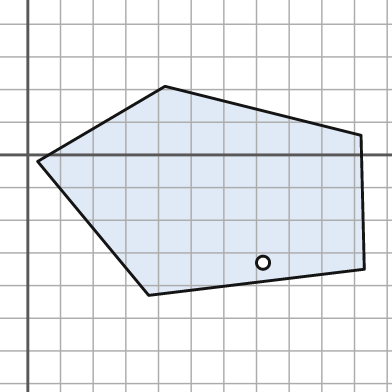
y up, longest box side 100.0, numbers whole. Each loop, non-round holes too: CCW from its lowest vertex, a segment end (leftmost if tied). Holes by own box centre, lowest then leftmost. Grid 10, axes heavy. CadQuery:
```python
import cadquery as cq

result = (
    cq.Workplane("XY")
    .moveTo(37.0, -43.0)
    .lineTo(103.0, -35.0)
    .lineTo(102.0, 6.0)
    .lineTo(42.0, 21.0)
    .lineTo(3.0, -2.0)
    .close()
    .moveTo(72.0, -33.0)
    .circle(2.0)
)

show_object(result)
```